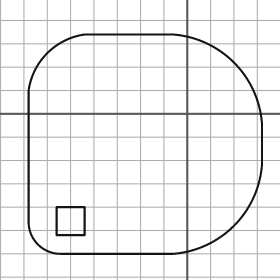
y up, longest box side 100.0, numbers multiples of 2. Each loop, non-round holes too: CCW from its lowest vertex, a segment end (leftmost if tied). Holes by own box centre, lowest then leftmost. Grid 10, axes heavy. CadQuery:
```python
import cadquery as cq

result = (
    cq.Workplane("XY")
    .moveTo(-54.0, -60.0)
    .lineTo(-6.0, -60.0)
    .threePointArc((20.0, -48.0), (32.0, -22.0))
    .lineTo(32.0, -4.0)
    .threePointArc((20.0, 22.0), (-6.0, 34.0))
    .lineTo(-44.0, 34.0)
    .threePointArc((-60.0, 26.0), (-68.0, 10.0))
    .lineTo(-68.0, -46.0)
    .threePointArc((-64.0, -56.0), (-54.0, -60.0))
    .close()
    .moveTo(-56.0, -52.0)
    .lineTo(-44.0, -52.0)
    .lineTo(-44.0, -40.0)
    .lineTo(-56.0, -40.0)
    .close()
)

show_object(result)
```